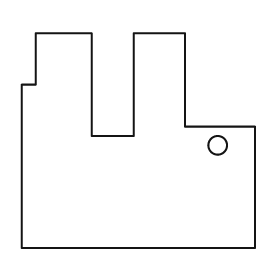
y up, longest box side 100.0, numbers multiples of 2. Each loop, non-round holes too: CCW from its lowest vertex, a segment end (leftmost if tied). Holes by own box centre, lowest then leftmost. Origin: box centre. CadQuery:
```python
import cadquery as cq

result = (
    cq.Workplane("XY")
    .moveTo(-50.0, -46.0)
    .lineTo(50.0, -46.0)
    .lineTo(50.0, 6.0)
    .lineTo(20.0, 6.0)
    .lineTo(20.0, 46.0)
    .lineTo(-2.0, 46.0)
    .lineTo(-2.0, 2.0)
    .lineTo(-20.0, 2.0)
    .lineTo(-20.0, 46.0)
    .lineTo(-44.0, 46.0)
    .lineTo(-44.0, 24.0)
    .lineTo(-50.0, 24.0)
    .close()
    .moveTo(34.0, -2.0)
    .circle(4.0)
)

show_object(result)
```